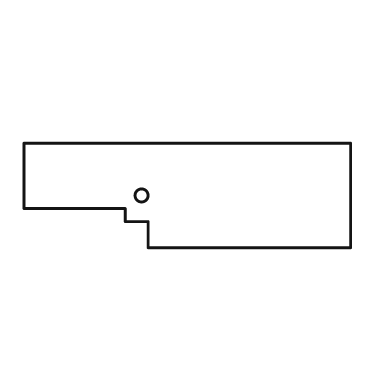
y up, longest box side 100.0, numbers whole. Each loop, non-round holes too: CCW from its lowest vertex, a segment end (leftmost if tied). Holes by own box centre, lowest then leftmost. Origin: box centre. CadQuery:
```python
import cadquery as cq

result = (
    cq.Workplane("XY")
    .moveTo(-12.0, -16.0)
    .lineTo(50.0, -16.0)
    .lineTo(50.0, 16.0)
    .lineTo(-50.0, 16.0)
    .lineTo(-50.0, -4.0)
    .lineTo(-19.0, -4.0)
    .lineTo(-19.0, -8.0)
    .lineTo(-12.0, -8.0)
    .close()
    .moveTo(-14.0, 0.0)
    .circle(2.0)
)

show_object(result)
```